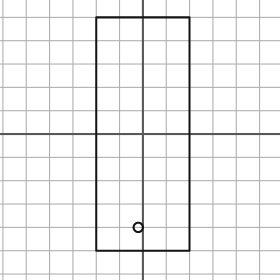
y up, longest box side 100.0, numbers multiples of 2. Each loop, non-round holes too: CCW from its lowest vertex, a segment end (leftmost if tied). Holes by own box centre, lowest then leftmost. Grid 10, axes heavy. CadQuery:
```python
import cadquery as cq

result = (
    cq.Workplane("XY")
    .moveTo(-20.0, -50.0)
    .lineTo(20.0, -50.0)
    .lineTo(20.0, 50.0)
    .lineTo(-20.0, 50.0)
    .close()
    .moveTo(-2.0, -40.0)
    .circle(2.0)
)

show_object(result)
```